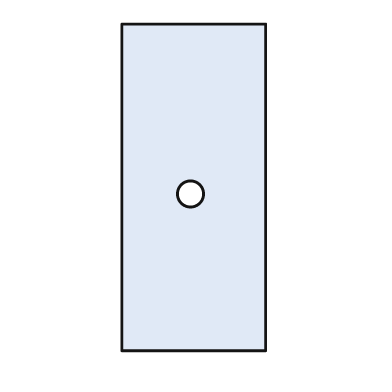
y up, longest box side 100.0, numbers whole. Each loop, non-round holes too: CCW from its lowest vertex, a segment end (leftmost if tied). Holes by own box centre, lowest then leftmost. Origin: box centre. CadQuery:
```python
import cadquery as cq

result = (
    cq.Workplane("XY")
    .moveTo(-22.0, -50.0)
    .lineTo(22.0, -50.0)
    .lineTo(22.0, 50.0)
    .lineTo(-22.0, 50.0)
    .close()
    .moveTo(-1.0, -2.0)
    .circle(4.0)
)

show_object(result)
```